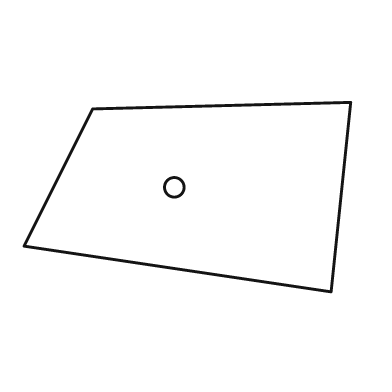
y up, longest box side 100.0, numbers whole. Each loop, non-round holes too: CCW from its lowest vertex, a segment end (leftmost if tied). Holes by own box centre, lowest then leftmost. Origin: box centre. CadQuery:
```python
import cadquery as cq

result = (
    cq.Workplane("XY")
    .moveTo(44.0, -29.0)
    .lineTo(50.0, 29.0)
    .lineTo(-29.0, 27.0)
    .lineTo(-50.0, -15.0)
    .close()
    .moveTo(-4.0, 3.0)
    .circle(3.0)
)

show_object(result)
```